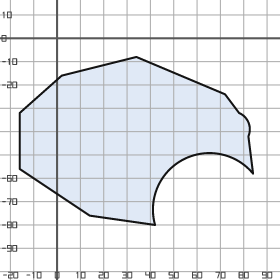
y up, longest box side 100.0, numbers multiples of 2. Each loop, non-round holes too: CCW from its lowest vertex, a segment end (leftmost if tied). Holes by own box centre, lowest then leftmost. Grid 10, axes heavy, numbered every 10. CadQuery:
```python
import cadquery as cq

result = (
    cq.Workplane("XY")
    .moveTo(42.0, -80.0)
    .threePointArc((54.0, -52.0), (84.0, -58.0))
    .lineTo(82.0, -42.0)
    .threePointArc((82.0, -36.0), (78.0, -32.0))
    .lineTo(72.0, -24.0)
    .lineTo(34.0, -8.0)
    .lineTo(2.0, -16.0)
    .lineTo(-16.0, -32.0)
    .lineTo(-16.0, -56.0)
    .lineTo(14.0, -76.0)
    .close()
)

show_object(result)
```